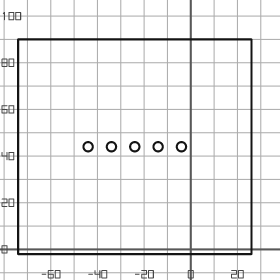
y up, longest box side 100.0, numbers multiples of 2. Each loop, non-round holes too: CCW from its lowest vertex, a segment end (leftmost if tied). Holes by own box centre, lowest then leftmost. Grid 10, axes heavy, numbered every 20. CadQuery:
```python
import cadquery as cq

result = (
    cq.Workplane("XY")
    .moveTo(-74.0, -2.0)
    .lineTo(26.0, -2.0)
    .lineTo(26.0, 90.0)
    .lineTo(-74.0, 90.0)
    .close()
    .moveTo(-44.0, 44.0)
    .circle(2.0)
    .moveTo(-34.0, 44.0)
    .circle(2.0)
    .moveTo(-24.0, 44.0)
    .circle(2.0)
    .moveTo(-14.0, 44.0)
    .circle(2.0)
    .moveTo(-4.0, 44.0)
    .circle(2.0)
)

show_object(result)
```